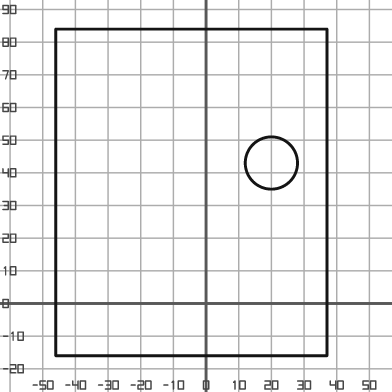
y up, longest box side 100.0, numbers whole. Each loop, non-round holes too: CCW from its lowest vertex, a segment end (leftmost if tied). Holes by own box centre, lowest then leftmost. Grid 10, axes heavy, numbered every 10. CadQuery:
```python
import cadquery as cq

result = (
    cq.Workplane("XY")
    .moveTo(-46.0, -16.0)
    .lineTo(37.0, -16.0)
    .lineTo(37.0, 84.0)
    .lineTo(-46.0, 84.0)
    .close()
    .moveTo(20.0, 43.0)
    .circle(8.0)
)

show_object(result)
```